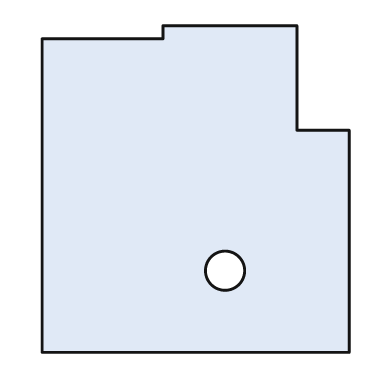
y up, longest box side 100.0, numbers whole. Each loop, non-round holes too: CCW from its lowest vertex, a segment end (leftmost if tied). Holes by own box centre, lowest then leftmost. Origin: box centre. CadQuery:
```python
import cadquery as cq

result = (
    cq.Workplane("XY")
    .moveTo(-47.0, -50.0)
    .lineTo(47.0, -50.0)
    .lineTo(47.0, 18.0)
    .lineTo(31.0, 18.0)
    .lineTo(31.0, 50.0)
    .lineTo(-10.0, 50.0)
    .lineTo(-10.0, 46.0)
    .lineTo(-47.0, 46.0)
    .close()
    .moveTo(9.0, -25.0)
    .circle(6.0)
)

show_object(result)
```